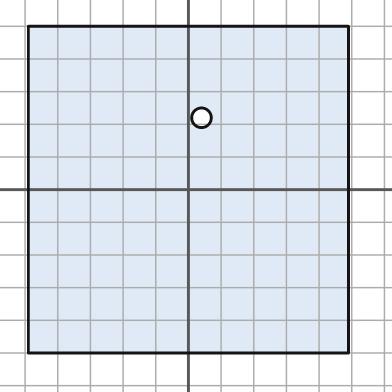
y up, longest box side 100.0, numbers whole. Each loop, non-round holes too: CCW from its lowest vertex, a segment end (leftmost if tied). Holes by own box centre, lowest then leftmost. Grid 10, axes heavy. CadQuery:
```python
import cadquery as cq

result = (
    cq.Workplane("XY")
    .moveTo(-49.0, -50.0)
    .lineTo(49.0, -50.0)
    .lineTo(49.0, 50.0)
    .lineTo(-49.0, 50.0)
    .close()
    .moveTo(4.0, 22.0)
    .circle(3.0)
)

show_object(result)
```